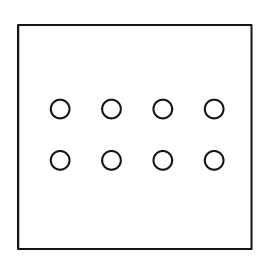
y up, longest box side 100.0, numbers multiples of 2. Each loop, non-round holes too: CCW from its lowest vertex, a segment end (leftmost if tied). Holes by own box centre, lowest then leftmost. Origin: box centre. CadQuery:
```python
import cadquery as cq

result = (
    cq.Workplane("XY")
    .moveTo(-50.0, -48.0)
    .lineTo(50.0, -48.0)
    .lineTo(50.0, 48.0)
    .lineTo(-50.0, 48.0)
    .close()
    .moveTo(-32.0, -10.0)
    .circle(4.0)
    .moveTo(-10.0, -10.0)
    .circle(4.0)
    .moveTo(12.0, -10.0)
    .circle(4.0)
    .moveTo(34.0, -10.0)
    .circle(4.0)
    .moveTo(-32.0, 12.0)
    .circle(4.0)
    .moveTo(-10.0, 12.0)
    .circle(4.0)
    .moveTo(12.0, 12.0)
    .circle(4.0)
    .moveTo(34.0, 12.0)
    .circle(4.0)
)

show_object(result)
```